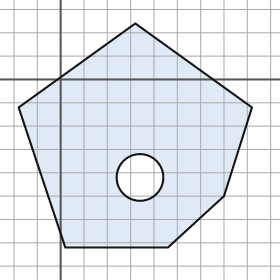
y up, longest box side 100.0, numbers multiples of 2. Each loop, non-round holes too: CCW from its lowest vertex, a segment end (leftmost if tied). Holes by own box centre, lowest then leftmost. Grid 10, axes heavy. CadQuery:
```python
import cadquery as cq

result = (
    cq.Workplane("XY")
    .moveTo(2.0, -72.0)
    .lineTo(46.0, -72.0)
    .lineTo(70.0, -50.0)
    .lineTo(82.0, -12.0)
    .lineTo(32.0, 24.0)
    .lineTo(-18.0, -12.0)
    .close()
    .moveTo(34.0, -42.0)
    .circle(10.0)
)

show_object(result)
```